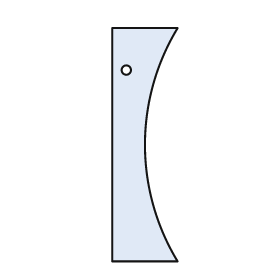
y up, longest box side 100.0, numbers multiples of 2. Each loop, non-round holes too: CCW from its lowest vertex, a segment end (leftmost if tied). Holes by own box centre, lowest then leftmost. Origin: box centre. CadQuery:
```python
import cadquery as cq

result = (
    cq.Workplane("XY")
    .moveTo(-14.0, -50.0)
    .lineTo(14.0, -50.0)
    .threePointArc((0.0, 0.0), (14.0, 50.0))
    .lineTo(-14.0, 50.0)
    .close()
    .moveTo(-8.0, 32.0)
    .circle(2.0)
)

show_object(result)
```